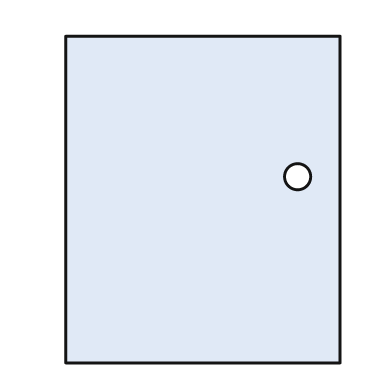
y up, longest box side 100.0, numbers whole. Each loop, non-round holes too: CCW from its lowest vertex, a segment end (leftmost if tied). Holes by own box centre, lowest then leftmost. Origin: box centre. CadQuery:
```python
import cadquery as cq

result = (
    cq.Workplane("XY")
    .moveTo(-42.0, -50.0)
    .lineTo(42.0, -50.0)
    .lineTo(42.0, 50.0)
    .lineTo(-42.0, 50.0)
    .close()
    .moveTo(29.0, 7.0)
    .circle(4.0)
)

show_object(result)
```